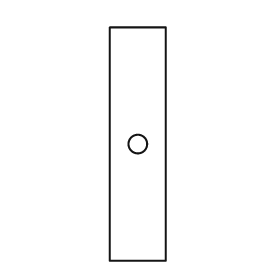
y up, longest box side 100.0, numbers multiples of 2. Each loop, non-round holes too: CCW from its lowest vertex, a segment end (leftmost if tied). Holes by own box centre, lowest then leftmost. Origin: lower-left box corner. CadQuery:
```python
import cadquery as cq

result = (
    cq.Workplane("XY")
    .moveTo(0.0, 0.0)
    .lineTo(24.0, 0.0)
    .lineTo(24.0, 100.0)
    .lineTo(0.0, 100.0)
    .close()
    .moveTo(12.0, 50.0)
    .circle(4.0)
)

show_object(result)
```